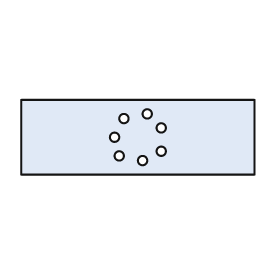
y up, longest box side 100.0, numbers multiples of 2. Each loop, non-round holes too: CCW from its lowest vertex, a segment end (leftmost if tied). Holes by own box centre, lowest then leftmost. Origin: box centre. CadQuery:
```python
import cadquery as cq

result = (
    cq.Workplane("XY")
    .moveTo(-50.0, -16.0)
    .lineTo(50.0, -16.0)
    .lineTo(50.0, 16.0)
    .lineTo(-50.0, 16.0)
    .close()
    .moveTo(2.0, -10.0)
    .circle(2.0)
    .moveTo(-8.0, -8.0)
    .circle(2.0)
    .moveTo(10.0, -6.0)
    .circle(2.0)
    .moveTo(-10.0, 0.0)
    .circle(2.0)
    .moveTo(10.0, 4.0)
    .circle(2.0)
    .moveTo(-6.0, 8.0)
    .circle(2.0)
    .moveTo(4.0, 10.0)
    .circle(2.0)
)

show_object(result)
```